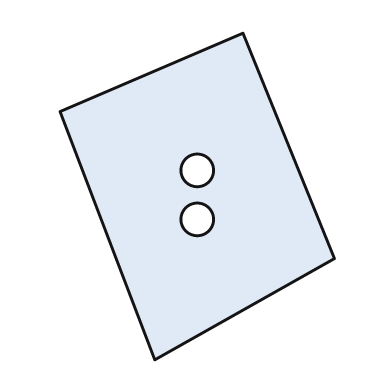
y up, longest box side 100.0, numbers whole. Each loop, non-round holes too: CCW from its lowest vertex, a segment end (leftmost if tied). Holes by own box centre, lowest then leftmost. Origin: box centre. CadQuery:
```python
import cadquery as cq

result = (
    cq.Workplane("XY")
    .moveTo(-13.0, -50.0)
    .lineTo(42.0, -19.0)
    .lineTo(14.0, 50.0)
    .lineTo(-42.0, 26.0)
    .close()
    .moveTo(0.0, -7.0)
    .circle(5.0)
    .moveTo(0.0, 8.0)
    .circle(5.0)
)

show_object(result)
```